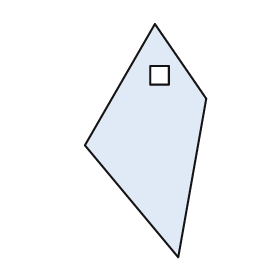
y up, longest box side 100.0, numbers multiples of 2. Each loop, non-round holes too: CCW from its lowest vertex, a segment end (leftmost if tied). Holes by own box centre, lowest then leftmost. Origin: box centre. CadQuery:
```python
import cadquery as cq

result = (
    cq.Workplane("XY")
    .moveTo(14.0, -50.0)
    .lineTo(26.0, 18.0)
    .lineTo(4.0, 50.0)
    .lineTo(-26.0, -2.0)
    .close()
    .moveTo(2.0, 24.0)
    .lineTo(10.0, 24.0)
    .lineTo(10.0, 32.0)
    .lineTo(2.0, 32.0)
    .close()
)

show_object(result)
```